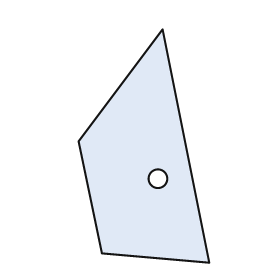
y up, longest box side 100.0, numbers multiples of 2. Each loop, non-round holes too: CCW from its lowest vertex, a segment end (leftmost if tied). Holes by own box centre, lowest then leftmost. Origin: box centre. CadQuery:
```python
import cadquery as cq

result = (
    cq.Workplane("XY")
    .moveTo(28.0, -50.0)
    .lineTo(8.0, 50.0)
    .lineTo(-28.0, 2.0)
    .lineTo(-18.0, -46.0)
    .close()
    .moveTo(6.0, -14.0)
    .circle(4.0)
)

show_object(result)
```